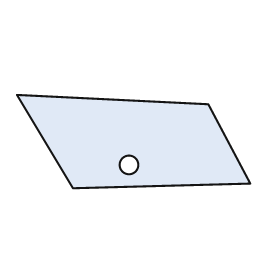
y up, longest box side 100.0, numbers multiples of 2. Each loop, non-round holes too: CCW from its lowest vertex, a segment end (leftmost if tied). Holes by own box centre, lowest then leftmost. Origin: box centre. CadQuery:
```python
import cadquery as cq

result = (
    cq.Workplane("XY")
    .moveTo(-26.0, -20.0)
    .lineTo(50.0, -18.0)
    .lineTo(32.0, 16.0)
    .lineTo(-50.0, 20.0)
    .close()
    .moveTo(-2.0, -10.0)
    .circle(4.0)
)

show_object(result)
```